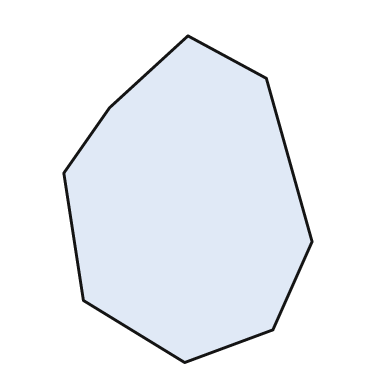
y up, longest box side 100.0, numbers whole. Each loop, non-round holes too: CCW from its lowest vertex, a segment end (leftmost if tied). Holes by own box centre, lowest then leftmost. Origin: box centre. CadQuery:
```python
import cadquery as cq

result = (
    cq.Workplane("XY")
    .moveTo(-1.0, -50.0)
    .lineTo(26.0, -40.0)
    .lineTo(38.0, -13.0)
    .lineTo(24.0, 37.0)
    .lineTo(0.0, 50.0)
    .lineTo(-24.0, 28.0)
    .lineTo(-38.0, 8.0)
    .lineTo(-32.0, -31.0)
    .close()
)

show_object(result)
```